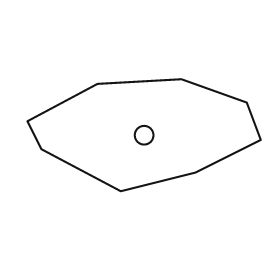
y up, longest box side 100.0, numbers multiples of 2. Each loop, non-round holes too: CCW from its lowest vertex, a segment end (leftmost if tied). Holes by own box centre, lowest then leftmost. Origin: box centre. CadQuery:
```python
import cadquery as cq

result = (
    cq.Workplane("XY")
    .moveTo(-10.0, -24.0)
    .lineTo(22.0, -16.0)
    .lineTo(50.0, -2.0)
    .lineTo(44.0, 14.0)
    .lineTo(16.0, 24.0)
    .lineTo(-20.0, 22.0)
    .lineTo(-50.0, 6.0)
    .lineTo(-44.0, -6.0)
    .close()
    .moveTo(0.0, 0.0)
    .circle(4.0)
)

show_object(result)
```